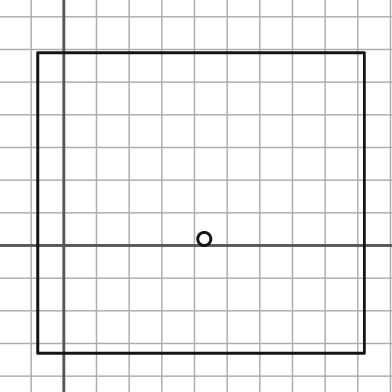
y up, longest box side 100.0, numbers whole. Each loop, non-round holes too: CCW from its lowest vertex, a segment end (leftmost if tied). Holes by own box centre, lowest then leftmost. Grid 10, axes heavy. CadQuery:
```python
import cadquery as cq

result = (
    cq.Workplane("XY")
    .moveTo(-8.0, -33.0)
    .lineTo(92.0, -33.0)
    .lineTo(92.0, 59.0)
    .lineTo(-8.0, 59.0)
    .close()
    .moveTo(43.0, 2.0)
    .circle(2.0)
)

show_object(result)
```